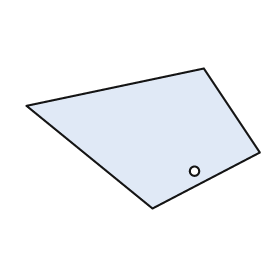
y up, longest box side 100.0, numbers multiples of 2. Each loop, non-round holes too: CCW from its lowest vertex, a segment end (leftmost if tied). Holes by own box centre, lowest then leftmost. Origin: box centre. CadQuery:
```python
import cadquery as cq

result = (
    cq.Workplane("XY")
    .moveTo(4.0, -30.0)
    .lineTo(50.0, -6.0)
    .lineTo(26.0, 30.0)
    .lineTo(-50.0, 14.0)
    .close()
    .moveTo(22.0, -14.0)
    .circle(2.0)
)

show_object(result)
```